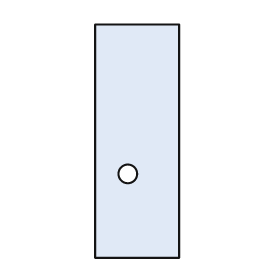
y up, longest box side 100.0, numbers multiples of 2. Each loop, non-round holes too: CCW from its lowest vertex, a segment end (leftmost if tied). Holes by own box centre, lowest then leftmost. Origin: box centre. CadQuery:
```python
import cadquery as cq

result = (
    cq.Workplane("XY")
    .moveTo(-18.0, -50.0)
    .lineTo(18.0, -50.0)
    .lineTo(18.0, 50.0)
    .lineTo(-18.0, 50.0)
    .close()
    .moveTo(-4.0, -14.0)
    .circle(4.0)
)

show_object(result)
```